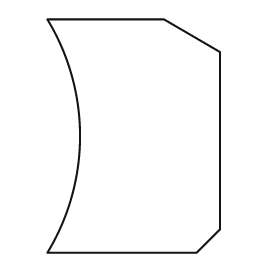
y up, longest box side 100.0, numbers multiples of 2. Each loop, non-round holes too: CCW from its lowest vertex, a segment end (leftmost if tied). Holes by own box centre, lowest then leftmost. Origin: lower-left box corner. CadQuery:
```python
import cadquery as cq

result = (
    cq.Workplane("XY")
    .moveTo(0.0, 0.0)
    .lineTo(64.0, 0.0)
    .lineTo(74.0, 10.0)
    .lineTo(74.0, 86.0)
    .lineTo(50.0, 100.0)
    .lineTo(0.0, 100.0)
    .threePointArc((14.0, 50.0), (0.0, 0.0))
    .close()
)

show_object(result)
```